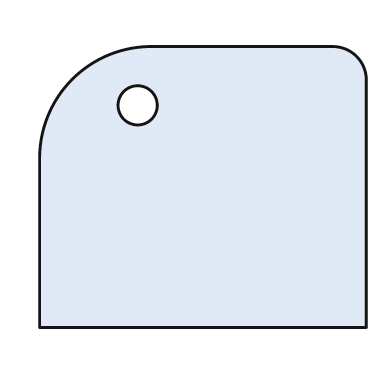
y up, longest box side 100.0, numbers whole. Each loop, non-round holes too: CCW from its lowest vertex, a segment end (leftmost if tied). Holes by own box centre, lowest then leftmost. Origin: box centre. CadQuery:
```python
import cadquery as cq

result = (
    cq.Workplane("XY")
    .moveTo(-50.0, -43.0)
    .lineTo(50.0, -43.0)
    .lineTo(50.0, 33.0)
    .threePointArc((47.0, 40.0), (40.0, 43.0))
    .lineTo(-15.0, 43.0)
    .threePointArc((-40.0, 33.0), (-50.0, 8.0))
    .close()
    .moveTo(-20.0, 25.0)
    .circle(6.0)
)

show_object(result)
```